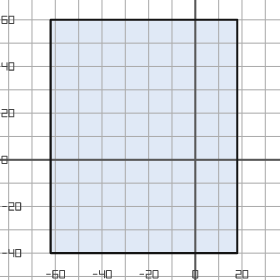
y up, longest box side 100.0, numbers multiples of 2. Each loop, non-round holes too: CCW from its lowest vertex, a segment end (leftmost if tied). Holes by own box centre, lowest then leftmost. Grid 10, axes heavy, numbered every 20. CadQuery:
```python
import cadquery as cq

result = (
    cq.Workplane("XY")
    .moveTo(-62.0, -40.0)
    .lineTo(18.0, -40.0)
    .lineTo(18.0, 60.0)
    .lineTo(-62.0, 60.0)
    .close()
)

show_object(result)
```